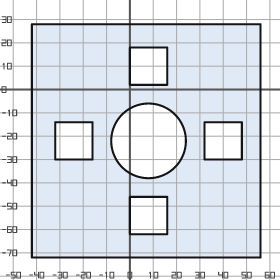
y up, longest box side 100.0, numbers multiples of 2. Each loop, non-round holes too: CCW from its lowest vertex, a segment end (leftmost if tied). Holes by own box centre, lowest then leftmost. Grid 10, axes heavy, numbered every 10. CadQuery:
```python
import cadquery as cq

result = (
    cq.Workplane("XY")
    .moveTo(-42.0, -72.0)
    .lineTo(56.0, -72.0)
    .lineTo(56.0, 28.0)
    .lineTo(-42.0, 28.0)
    .close()
    .moveTo(0.0, -62.0)
    .lineTo(16.0, -62.0)
    .lineTo(16.0, -46.0)
    .lineTo(0.0, -46.0)
    .close()
    .moveTo(-32.0, -30.0)
    .lineTo(-16.0, -30.0)
    .lineTo(-16.0, -14.0)
    .lineTo(-32.0, -14.0)
    .close()
    .moveTo(8.0, -22.0)
    .circle(16.0)
    .moveTo(32.0, -30.0)
    .lineTo(48.0, -30.0)
    .lineTo(48.0, -14.0)
    .lineTo(32.0, -14.0)
    .close()
    .moveTo(0.0, 2.0)
    .lineTo(16.0, 2.0)
    .lineTo(16.0, 18.0)
    .lineTo(0.0, 18.0)
    .close()
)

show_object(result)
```